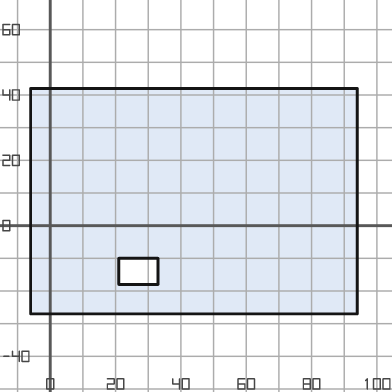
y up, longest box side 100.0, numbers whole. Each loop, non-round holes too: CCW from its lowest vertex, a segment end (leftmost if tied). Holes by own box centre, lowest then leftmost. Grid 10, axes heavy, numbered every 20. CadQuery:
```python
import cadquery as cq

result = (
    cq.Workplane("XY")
    .moveTo(-6.0, -27.0)
    .lineTo(94.0, -27.0)
    .lineTo(94.0, 42.0)
    .lineTo(-6.0, 42.0)
    .close()
    .moveTo(21.0, -18.0)
    .lineTo(33.0, -18.0)
    .lineTo(33.0, -10.0)
    .lineTo(21.0, -10.0)
    .close()
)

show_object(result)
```